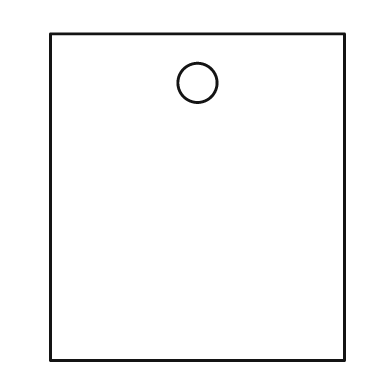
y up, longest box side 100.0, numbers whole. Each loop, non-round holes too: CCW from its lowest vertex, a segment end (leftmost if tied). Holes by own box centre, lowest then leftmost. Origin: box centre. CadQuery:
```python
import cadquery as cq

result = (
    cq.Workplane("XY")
    .moveTo(-45.0, -50.0)
    .lineTo(45.0, -50.0)
    .lineTo(45.0, 50.0)
    .lineTo(-45.0, 50.0)
    .close()
    .moveTo(0.0, 35.0)
    .circle(6.0)
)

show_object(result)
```